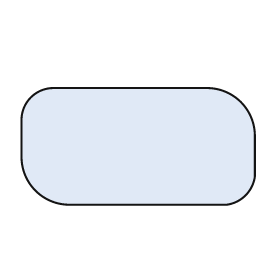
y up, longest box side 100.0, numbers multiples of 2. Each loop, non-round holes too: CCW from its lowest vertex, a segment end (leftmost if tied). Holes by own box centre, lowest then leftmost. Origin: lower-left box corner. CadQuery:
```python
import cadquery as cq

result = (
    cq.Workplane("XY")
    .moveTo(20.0, 0.0)
    .lineTo(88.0, 0.0)
    .threePointArc((96.0, 4.0), (100.0, 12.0))
    .lineTo(100.0, 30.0)
    .threePointArc((94.0, 44.0), (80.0, 50.0))
    .lineTo(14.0, 50.0)
    .threePointArc((4.0, 46.0), (0.0, 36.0))
    .lineTo(0.0, 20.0)
    .threePointArc((6.0, 6.0), (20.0, 0.0))
    .close()
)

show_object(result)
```